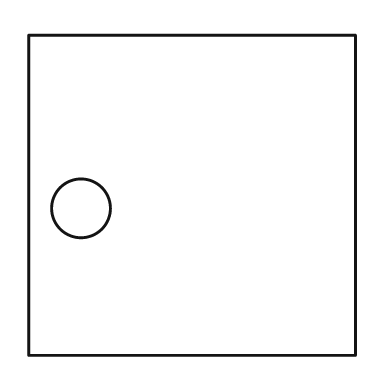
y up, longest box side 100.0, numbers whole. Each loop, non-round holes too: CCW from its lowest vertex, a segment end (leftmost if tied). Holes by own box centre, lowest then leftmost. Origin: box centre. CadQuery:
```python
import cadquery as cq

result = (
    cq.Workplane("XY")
    .moveTo(-50.0, -49.0)
    .lineTo(50.0, -49.0)
    .lineTo(50.0, 49.0)
    .lineTo(-50.0, 49.0)
    .close()
    .moveTo(-34.0, -4.0)
    .circle(9.0)
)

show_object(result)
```